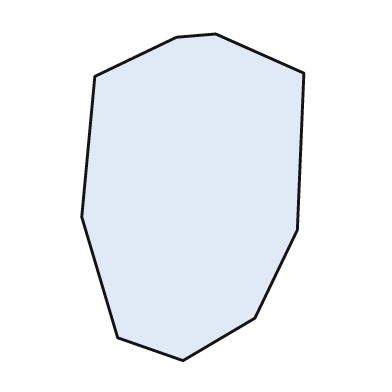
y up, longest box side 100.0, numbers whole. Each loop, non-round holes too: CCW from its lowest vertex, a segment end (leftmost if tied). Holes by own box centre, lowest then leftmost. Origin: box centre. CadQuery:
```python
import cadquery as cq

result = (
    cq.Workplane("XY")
    .moveTo(-3.0, -50.0)
    .lineTo(19.0, -37.0)
    .lineTo(32.0, -10.0)
    .lineTo(34.0, 38.0)
    .lineTo(7.0, 50.0)
    .lineTo(-5.0, 49.0)
    .lineTo(-30.0, 37.0)
    .lineTo(-34.0, -6.0)
    .lineTo(-23.0, -43.0)
    .close()
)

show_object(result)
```